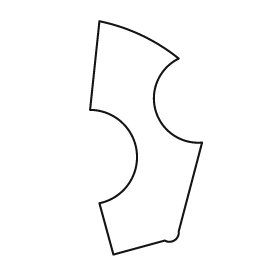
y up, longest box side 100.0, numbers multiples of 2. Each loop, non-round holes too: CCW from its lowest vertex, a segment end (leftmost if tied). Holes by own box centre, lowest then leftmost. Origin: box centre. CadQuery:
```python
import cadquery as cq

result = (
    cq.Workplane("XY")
    .moveTo(-14.0, -50.0)
    .lineTo(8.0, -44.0)
    .threePointArc((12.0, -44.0), (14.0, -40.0))
    .lineTo(24.0, -2.0)
    .threePointArc((4.0, 12.0), (14.0, 34.0))
    .threePointArc((-2.0, 44.0), (-20.0, 50.0))
    .lineTo(-24.0, 12.0)
    .threePointArc((-4.0, -6.0), (-20.0, -28.0))
    .close()
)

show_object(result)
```